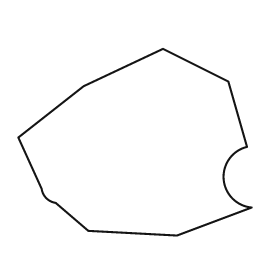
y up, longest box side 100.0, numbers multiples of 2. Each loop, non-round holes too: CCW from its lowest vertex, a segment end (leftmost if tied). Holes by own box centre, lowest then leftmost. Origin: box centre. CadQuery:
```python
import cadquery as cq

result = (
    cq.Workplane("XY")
    .moveTo(18.0, -40.0)
    .lineTo(50.0, -28.0)
    .threePointArc((38.0, -16.0), (48.0, -2.0))
    .lineTo(40.0, 26.0)
    .lineTo(12.0, 40.0)
    .lineTo(-22.0, 24.0)
    .lineTo(-50.0, 2.0)
    .lineTo(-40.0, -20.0)
    .threePointArc((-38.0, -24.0), (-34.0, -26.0))
    .lineTo(-20.0, -38.0)
    .close()
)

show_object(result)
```